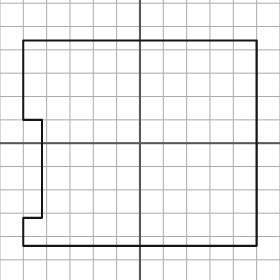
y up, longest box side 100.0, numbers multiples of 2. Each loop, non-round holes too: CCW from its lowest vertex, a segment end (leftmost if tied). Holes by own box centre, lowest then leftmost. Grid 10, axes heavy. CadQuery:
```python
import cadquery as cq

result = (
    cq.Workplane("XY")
    .moveTo(-50.0, -44.0)
    .lineTo(50.0, -44.0)
    .lineTo(50.0, 44.0)
    .lineTo(-50.0, 44.0)
    .lineTo(-50.0, 10.0)
    .lineTo(-42.0, 10.0)
    .lineTo(-42.0, -32.0)
    .lineTo(-50.0, -32.0)
    .close()
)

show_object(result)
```